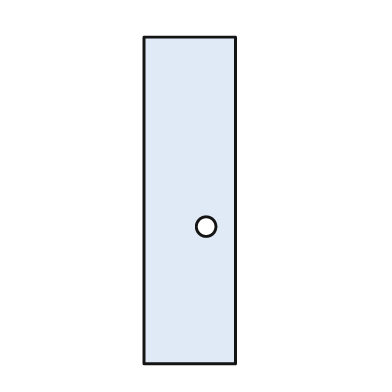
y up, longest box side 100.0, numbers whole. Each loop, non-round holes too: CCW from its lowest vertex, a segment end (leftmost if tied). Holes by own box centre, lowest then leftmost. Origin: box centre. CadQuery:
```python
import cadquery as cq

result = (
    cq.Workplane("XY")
    .moveTo(-14.0, -50.0)
    .lineTo(14.0, -50.0)
    .lineTo(14.0, 50.0)
    .lineTo(-14.0, 50.0)
    .close()
    .moveTo(5.0, -8.0)
    .circle(3.0)
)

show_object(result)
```